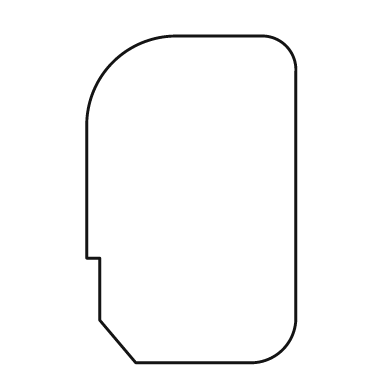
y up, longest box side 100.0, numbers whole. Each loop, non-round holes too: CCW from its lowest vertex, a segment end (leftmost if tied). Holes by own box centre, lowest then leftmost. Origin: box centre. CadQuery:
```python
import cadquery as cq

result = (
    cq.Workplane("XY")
    .moveTo(-17.0, -50.0)
    .lineTo(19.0, -50.0)
    .threePointArc((28.0, -46.0), (32.0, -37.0))
    .lineTo(32.0, 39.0)
    .threePointArc((29.0, 47.0), (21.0, 50.0))
    .lineTo(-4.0, 50.0)
    .threePointArc((-24.0, 42.0), (-32.0, 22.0))
    .lineTo(-32.0, -18.0)
    .lineTo(-28.0, -18.0)
    .lineTo(-28.0, -37.0)
    .close()
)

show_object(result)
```